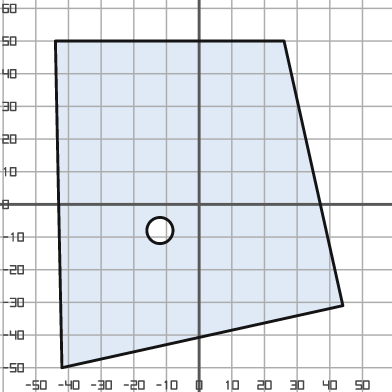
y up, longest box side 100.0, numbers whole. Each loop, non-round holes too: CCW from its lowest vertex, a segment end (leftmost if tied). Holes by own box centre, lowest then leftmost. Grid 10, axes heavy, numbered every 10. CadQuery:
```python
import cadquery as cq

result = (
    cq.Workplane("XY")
    .moveTo(-42.0, -50.0)
    .lineTo(44.0, -31.0)
    .lineTo(26.0, 50.0)
    .lineTo(-44.0, 50.0)
    .close()
    .moveTo(-12.0, -8.0)
    .circle(4.0)
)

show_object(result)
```